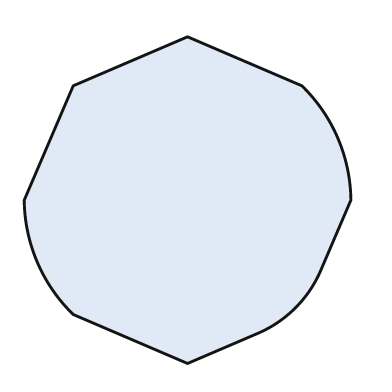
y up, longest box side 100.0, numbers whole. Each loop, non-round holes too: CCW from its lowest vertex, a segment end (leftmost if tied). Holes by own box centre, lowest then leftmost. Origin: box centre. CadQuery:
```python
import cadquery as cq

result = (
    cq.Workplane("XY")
    .moveTo(0.0, -50.0)
    .lineTo(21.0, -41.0)
    .threePointArc((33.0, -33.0), (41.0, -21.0))
    .lineTo(50.0, 0.0)
    .threePointArc((46.0, 19.0), (35.0, 35.0))
    .lineTo(0.0, 50.0)
    .lineTo(-35.0, 35.0)
    .lineTo(-50.0, 0.0)
    .threePointArc((-46.0, -19.0), (-35.0, -35.0))
    .close()
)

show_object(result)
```